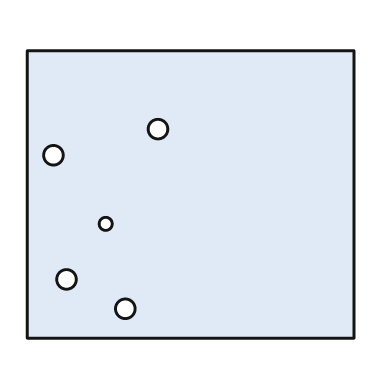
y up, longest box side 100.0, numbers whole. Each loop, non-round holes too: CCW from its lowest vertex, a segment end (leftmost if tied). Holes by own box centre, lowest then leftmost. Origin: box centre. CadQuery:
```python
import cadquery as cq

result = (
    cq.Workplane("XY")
    .moveTo(-50.0, -44.0)
    .lineTo(50.0, -44.0)
    .lineTo(50.0, 44.0)
    .lineTo(-50.0, 44.0)
    .close()
    .moveTo(-20.0, -35.0)
    .circle(3.0)
    .moveTo(-38.0, -26.0)
    .circle(3.0)
    .moveTo(-26.0, -9.0)
    .circle(2.0)
    .moveTo(-42.0, 12.0)
    .circle(3.0)
    .moveTo(-10.0, 20.0)
    .circle(3.0)
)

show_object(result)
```